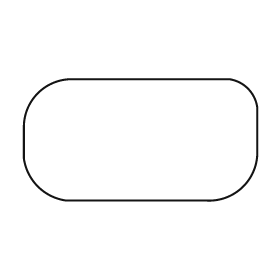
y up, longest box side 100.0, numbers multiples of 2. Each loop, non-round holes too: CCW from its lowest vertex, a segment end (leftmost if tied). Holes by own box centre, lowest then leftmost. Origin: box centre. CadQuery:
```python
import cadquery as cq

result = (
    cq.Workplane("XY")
    .moveTo(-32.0, -26.0)
    .lineTo(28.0, -26.0)
    .threePointArc((44.0, -20.0), (50.0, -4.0))
    .lineTo(50.0, 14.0)
    .threePointArc((46.0, 22.0), (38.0, 26.0))
    .lineTo(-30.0, 26.0)
    .threePointArc((-44.0, 20.0), (-50.0, 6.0))
    .lineTo(-50.0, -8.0)
    .threePointArc((-44.0, -20.0), (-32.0, -26.0))
    .close()
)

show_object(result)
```